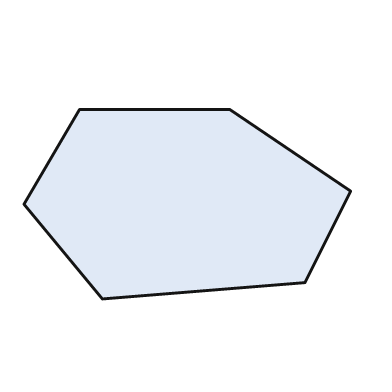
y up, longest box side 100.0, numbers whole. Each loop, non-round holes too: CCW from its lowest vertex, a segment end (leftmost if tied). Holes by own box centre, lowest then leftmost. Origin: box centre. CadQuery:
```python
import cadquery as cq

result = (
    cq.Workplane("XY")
    .moveTo(-26.0, -29.0)
    .lineTo(36.0, -24.0)
    .lineTo(50.0, 4.0)
    .lineTo(13.0, 29.0)
    .lineTo(-33.0, 29.0)
    .lineTo(-50.0, 0.0)
    .close()
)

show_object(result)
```